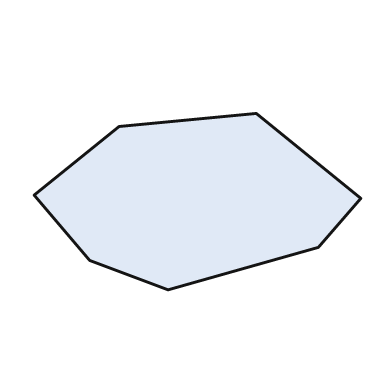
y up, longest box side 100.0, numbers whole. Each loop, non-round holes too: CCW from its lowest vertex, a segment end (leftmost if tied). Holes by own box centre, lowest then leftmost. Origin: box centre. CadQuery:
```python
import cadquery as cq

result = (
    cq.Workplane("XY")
    .moveTo(-9.0, -27.0)
    .lineTo(37.0, -14.0)
    .lineTo(50.0, 1.0)
    .lineTo(18.0, 27.0)
    .lineTo(-24.0, 23.0)
    .lineTo(-50.0, 2.0)
    .lineTo(-33.0, -18.0)
    .close()
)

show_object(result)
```